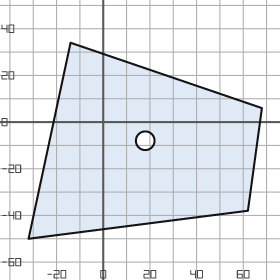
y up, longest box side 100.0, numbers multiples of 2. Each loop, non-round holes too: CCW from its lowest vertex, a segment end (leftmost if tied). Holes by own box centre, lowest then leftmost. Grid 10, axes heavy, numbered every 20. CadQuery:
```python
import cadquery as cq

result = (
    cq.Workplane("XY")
    .moveTo(-32.0, -50.0)
    .lineTo(62.0, -38.0)
    .lineTo(68.0, 6.0)
    .lineTo(-14.0, 34.0)
    .close()
    .moveTo(18.0, -8.0)
    .circle(4.0)
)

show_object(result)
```